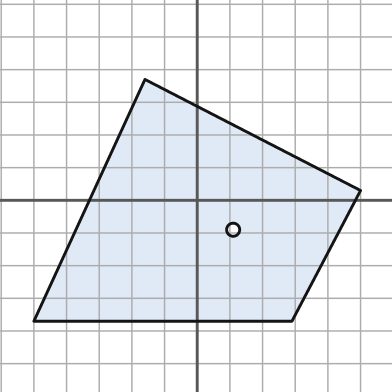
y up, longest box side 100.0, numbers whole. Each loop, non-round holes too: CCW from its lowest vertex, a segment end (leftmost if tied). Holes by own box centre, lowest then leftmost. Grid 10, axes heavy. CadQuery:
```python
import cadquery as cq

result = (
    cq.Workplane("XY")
    .moveTo(-50.0, -37.0)
    .lineTo(29.0, -37.0)
    .lineTo(50.0, 3.0)
    .lineTo(-16.0, 37.0)
    .close()
    .moveTo(11.0, -9.0)
    .circle(2.0)
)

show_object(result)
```